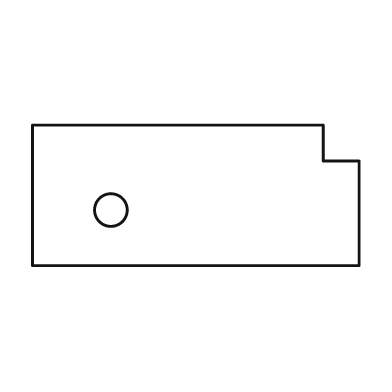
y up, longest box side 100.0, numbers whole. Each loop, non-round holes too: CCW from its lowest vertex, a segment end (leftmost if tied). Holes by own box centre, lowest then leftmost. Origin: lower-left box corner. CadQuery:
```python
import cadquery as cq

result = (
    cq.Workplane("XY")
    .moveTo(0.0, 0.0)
    .lineTo(100.0, 0.0)
    .lineTo(100.0, 32.0)
    .lineTo(89.0, 32.0)
    .lineTo(89.0, 43.0)
    .lineTo(0.0, 43.0)
    .close()
    .moveTo(24.0, 17.0)
    .circle(5.0)
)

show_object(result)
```